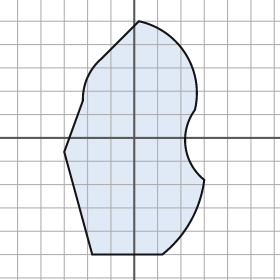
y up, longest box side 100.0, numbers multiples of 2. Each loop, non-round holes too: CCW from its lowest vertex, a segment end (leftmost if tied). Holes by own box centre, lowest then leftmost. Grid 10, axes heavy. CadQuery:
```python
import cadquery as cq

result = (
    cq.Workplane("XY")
    .moveTo(-18.0, -50.0)
    .lineTo(12.0, -50.0)
    .threePointArc((24.0, -36.0), (30.0, -18.0))
    .threePointArc((22.0, -4.0), (26.0, 12.0))
    .threePointArc((22.0, 36.0), (2.0, 50.0))
    .lineTo(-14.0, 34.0)
    .threePointArc((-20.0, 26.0), (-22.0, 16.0))
    .lineTo(-30.0, -6.0)
    .close()
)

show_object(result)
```